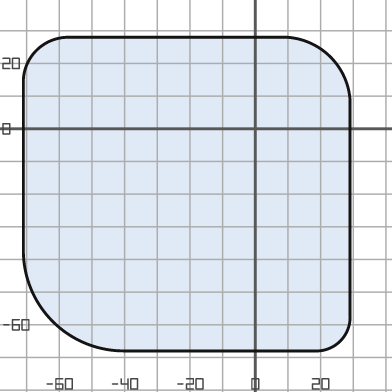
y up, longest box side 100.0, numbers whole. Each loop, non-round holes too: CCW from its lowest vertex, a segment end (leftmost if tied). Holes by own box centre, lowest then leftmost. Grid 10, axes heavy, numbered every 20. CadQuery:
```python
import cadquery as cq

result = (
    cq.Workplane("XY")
    .moveTo(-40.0, -68.0)
    .lineTo(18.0, -68.0)
    .threePointArc((26.0, -65.0), (29.0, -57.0))
    .lineTo(29.0, 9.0)
    .threePointArc((23.0, 22.0), (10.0, 28.0))
    .lineTo(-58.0, 28.0)
    .threePointArc((-67.0, 24.0), (-71.0, 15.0))
    .lineTo(-71.0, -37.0)
    .threePointArc((-62.0, -59.0), (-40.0, -68.0))
    .close()
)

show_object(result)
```